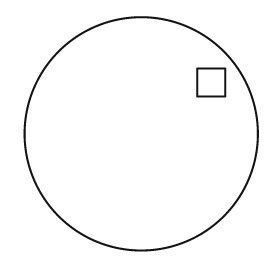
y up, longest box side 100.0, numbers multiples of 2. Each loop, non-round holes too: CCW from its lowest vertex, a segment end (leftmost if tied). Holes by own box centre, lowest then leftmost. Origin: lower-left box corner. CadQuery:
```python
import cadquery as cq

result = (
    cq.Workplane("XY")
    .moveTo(50.0, 50.0)
    .circle(50.0)
    .moveTo(74.0, 66.0)
    .lineTo(86.0, 66.0)
    .lineTo(86.0, 78.0)
    .lineTo(74.0, 78.0)
    .close()
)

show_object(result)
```